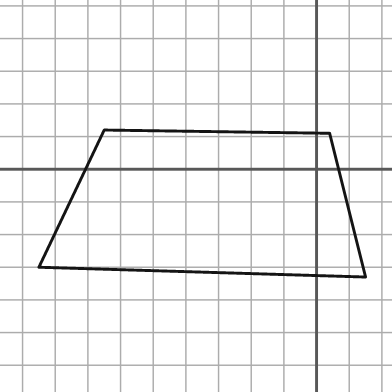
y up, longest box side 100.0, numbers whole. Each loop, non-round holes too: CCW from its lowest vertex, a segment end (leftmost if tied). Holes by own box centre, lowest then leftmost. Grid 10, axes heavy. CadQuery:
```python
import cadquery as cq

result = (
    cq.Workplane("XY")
    .moveTo(15.0, -33.0)
    .lineTo(4.0, 11.0)
    .lineTo(-65.0, 12.0)
    .lineTo(-85.0, -30.0)
    .close()
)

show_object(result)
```